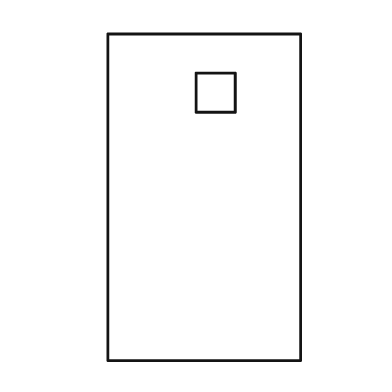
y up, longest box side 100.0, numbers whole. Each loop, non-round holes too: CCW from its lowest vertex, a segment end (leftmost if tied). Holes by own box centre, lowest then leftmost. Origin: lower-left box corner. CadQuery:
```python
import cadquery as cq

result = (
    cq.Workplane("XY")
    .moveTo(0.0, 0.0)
    .lineTo(59.0, 0.0)
    .lineTo(59.0, 100.0)
    .lineTo(0.0, 100.0)
    .close()
    .moveTo(27.0, 76.0)
    .lineTo(39.0, 76.0)
    .lineTo(39.0, 88.0)
    .lineTo(27.0, 88.0)
    .close()
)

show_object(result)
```